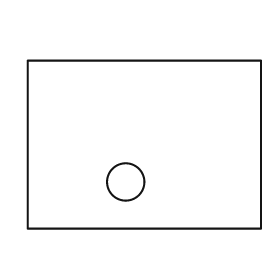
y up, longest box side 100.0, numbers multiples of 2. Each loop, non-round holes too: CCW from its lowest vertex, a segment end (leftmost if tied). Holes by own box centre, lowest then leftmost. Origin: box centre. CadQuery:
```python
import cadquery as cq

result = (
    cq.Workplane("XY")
    .moveTo(-50.0, -36.0)
    .lineTo(50.0, -36.0)
    .lineTo(50.0, 36.0)
    .lineTo(-50.0, 36.0)
    .close()
    .moveTo(-8.0, -16.0)
    .circle(8.0)
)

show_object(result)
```